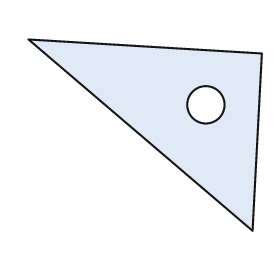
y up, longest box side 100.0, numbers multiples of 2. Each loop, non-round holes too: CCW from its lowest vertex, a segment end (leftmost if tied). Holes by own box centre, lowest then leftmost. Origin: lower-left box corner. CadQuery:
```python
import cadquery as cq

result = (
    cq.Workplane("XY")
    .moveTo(96.0, 0.0)
    .lineTo(100.0, 76.0)
    .lineTo(0.0, 82.0)
    .close()
    .moveTo(76.0, 54.0)
    .circle(8.0)
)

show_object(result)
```